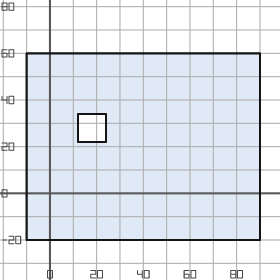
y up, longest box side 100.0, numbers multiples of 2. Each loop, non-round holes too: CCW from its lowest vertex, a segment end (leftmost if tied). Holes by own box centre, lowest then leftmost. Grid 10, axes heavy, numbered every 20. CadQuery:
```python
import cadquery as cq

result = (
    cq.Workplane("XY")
    .moveTo(-10.0, -20.0)
    .lineTo(90.0, -20.0)
    .lineTo(90.0, 60.0)
    .lineTo(-10.0, 60.0)
    .close()
    .moveTo(12.0, 22.0)
    .lineTo(24.0, 22.0)
    .lineTo(24.0, 34.0)
    .lineTo(12.0, 34.0)
    .close()
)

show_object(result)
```